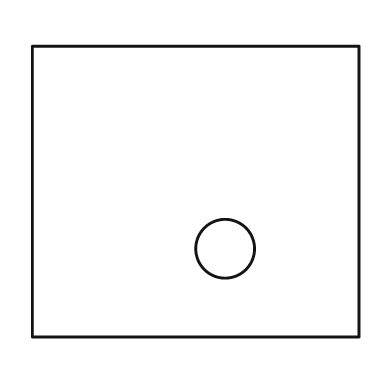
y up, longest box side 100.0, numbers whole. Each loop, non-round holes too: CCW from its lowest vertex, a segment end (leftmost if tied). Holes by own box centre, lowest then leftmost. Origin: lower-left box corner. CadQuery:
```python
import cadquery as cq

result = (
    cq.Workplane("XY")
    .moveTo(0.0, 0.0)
    .lineTo(100.0, 0.0)
    .lineTo(100.0, 89.0)
    .lineTo(0.0, 89.0)
    .close()
    .moveTo(59.0, 27.0)
    .circle(9.0)
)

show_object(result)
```